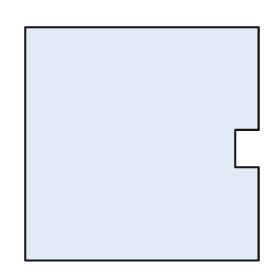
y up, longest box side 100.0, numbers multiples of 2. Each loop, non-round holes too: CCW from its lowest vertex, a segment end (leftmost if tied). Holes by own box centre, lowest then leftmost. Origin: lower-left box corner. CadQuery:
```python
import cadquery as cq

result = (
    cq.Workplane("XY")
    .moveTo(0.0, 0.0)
    .lineTo(100.0, 0.0)
    .lineTo(100.0, 40.0)
    .lineTo(90.0, 40.0)
    .lineTo(90.0, 56.0)
    .lineTo(100.0, 56.0)
    .lineTo(100.0, 100.0)
    .lineTo(0.0, 100.0)
    .close()
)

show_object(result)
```